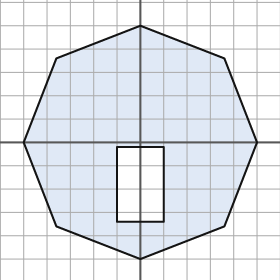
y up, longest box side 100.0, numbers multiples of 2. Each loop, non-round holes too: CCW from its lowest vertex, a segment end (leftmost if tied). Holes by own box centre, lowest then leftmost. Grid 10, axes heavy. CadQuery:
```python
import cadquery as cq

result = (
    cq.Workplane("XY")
    .moveTo(0.0, -50.0)
    .lineTo(36.0, -36.0)
    .lineTo(50.0, 0.0)
    .lineTo(36.0, 36.0)
    .lineTo(0.0, 50.0)
    .lineTo(-36.0, 36.0)
    .lineTo(-50.0, 0.0)
    .lineTo(-36.0, -36.0)
    .close()
    .moveTo(-10.0, -34.0)
    .lineTo(10.0, -34.0)
    .lineTo(10.0, -2.0)
    .lineTo(-10.0, -2.0)
    .close()
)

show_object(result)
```